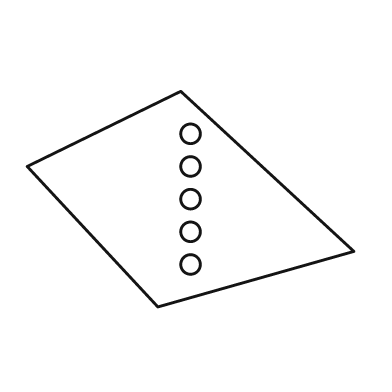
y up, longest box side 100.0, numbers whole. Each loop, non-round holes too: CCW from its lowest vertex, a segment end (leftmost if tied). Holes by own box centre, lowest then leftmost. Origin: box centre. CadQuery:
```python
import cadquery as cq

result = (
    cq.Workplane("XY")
    .moveTo(-10.0, -33.0)
    .lineTo(50.0, -16.0)
    .lineTo(-3.0, 33.0)
    .lineTo(-50.0, 10.0)
    .close()
    .moveTo(0.0, -20.0)
    .circle(3.0)
    .moveTo(0.0, -10.0)
    .circle(3.0)
    .moveTo(0.0, 0.0)
    .circle(3.0)
    .moveTo(0.0, 10.0)
    .circle(3.0)
    .moveTo(0.0, 20.0)
    .circle(3.0)
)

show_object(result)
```